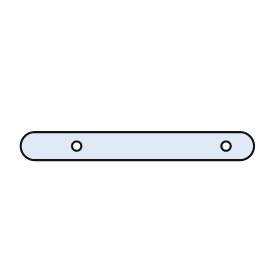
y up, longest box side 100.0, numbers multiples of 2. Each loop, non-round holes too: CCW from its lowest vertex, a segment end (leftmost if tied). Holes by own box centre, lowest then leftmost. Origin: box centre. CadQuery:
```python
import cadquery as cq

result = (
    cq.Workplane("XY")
    .moveTo(-44.0, -6.0)
    .lineTo(44.0, -6.0)
    .threePointArc((50.0, 0.0), (44.0, 6.0))
    .lineTo(-44.0, 6.0)
    .threePointArc((-50.0, 0.0), (-44.0, -6.0))
    .close()
    .moveTo(-26.0, 0.0)
    .circle(2.0)
    .moveTo(38.0, 0.0)
    .circle(2.0)
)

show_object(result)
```